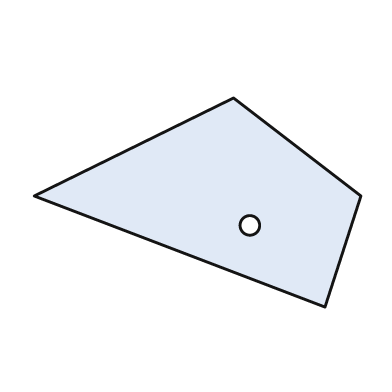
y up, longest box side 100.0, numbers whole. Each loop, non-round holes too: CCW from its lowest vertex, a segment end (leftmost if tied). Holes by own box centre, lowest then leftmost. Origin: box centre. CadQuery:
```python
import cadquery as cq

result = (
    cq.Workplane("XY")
    .moveTo(39.0, -32.0)
    .lineTo(50.0, 2.0)
    .lineTo(11.0, 32.0)
    .lineTo(-50.0, 2.0)
    .close()
    .moveTo(16.0, -7.0)
    .circle(3.0)
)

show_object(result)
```